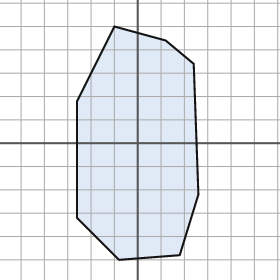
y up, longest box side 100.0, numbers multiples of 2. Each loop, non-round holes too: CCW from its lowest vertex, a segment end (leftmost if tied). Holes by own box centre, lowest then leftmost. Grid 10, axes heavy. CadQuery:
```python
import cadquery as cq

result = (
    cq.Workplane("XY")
    .moveTo(-8.0, -50.0)
    .lineTo(18.0, -48.0)
    .lineTo(26.0, -22.0)
    .lineTo(24.0, 34.0)
    .lineTo(12.0, 44.0)
    .lineTo(-10.0, 50.0)
    .lineTo(-26.0, 18.0)
    .lineTo(-26.0, -32.0)
    .close()
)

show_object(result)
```